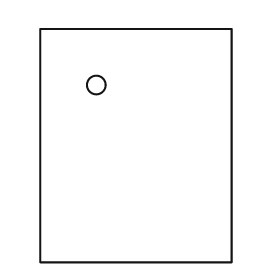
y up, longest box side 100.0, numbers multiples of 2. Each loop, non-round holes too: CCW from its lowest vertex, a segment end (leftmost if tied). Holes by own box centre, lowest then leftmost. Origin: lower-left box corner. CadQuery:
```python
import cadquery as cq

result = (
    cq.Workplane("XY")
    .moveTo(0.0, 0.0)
    .lineTo(82.0, 0.0)
    .lineTo(82.0, 100.0)
    .lineTo(0.0, 100.0)
    .close()
    .moveTo(24.0, 76.0)
    .circle(4.0)
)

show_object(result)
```